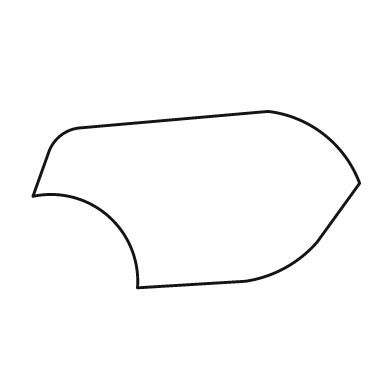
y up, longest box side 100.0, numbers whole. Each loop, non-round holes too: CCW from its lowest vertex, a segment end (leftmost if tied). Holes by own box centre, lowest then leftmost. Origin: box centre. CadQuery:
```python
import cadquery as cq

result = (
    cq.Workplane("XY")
    .moveTo(-18.0, -27.0)
    .lineTo(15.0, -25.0)
    .threePointArc((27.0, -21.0), (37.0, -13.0))
    .lineTo(50.0, 5.0)
    .threePointArc((39.0, 20.0), (22.0, 27.0))
    .lineTo(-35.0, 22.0)
    .threePointArc((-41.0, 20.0), (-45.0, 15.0))
    .lineTo(-50.0, 1.0)
    .threePointArc((-27.0, -5.0), (-18.0, -27.0))
    .close()
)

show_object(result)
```